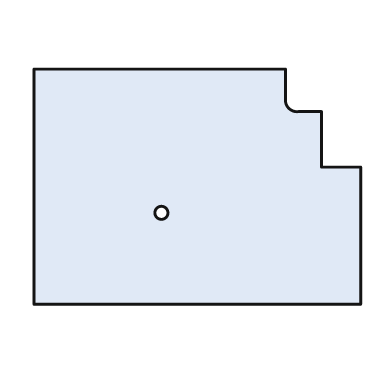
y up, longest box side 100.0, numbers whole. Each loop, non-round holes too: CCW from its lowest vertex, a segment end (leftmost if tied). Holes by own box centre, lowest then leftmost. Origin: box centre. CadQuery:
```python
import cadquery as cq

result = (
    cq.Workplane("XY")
    .moveTo(-50.0, -36.0)
    .lineTo(50.0, -36.0)
    .lineTo(50.0, 6.0)
    .lineTo(38.0, 6.0)
    .lineTo(38.0, 23.0)
    .lineTo(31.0, 23.0)
    .threePointArc((28.0, 24.0), (27.0, 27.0))
    .lineTo(27.0, 36.0)
    .lineTo(-50.0, 36.0)
    .close()
    .moveTo(-11.0, -8.0)
    .circle(2.0)
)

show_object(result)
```